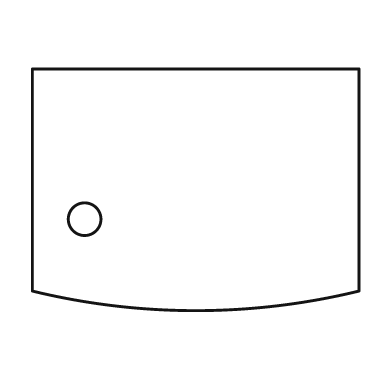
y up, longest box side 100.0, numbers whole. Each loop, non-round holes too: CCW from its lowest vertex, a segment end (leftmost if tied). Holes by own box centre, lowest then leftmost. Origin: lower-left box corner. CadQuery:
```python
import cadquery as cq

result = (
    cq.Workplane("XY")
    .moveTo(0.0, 6.0)
    .threePointArc((50.0, 0.0), (100.0, 6.0))
    .lineTo(100.0, 74.0)
    .lineTo(0.0, 74.0)
    .close()
    .moveTo(16.0, 28.0)
    .circle(5.0)
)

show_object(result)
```